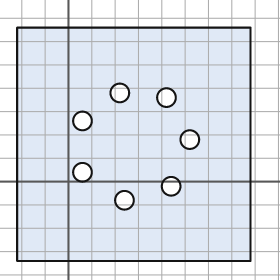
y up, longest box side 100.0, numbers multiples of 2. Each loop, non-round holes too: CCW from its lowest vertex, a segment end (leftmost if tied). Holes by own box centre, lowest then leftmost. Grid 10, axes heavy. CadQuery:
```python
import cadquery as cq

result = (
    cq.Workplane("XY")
    .moveTo(-22.0, -34.0)
    .lineTo(78.0, -34.0)
    .lineTo(78.0, 66.0)
    .lineTo(-22.0, 66.0)
    .close()
    .moveTo(24.0, -8.0)
    .circle(4.0)
    .moveTo(44.0, -2.0)
    .circle(4.0)
    .moveTo(6.0, 4.0)
    .circle(4.0)
    .moveTo(52.0, 18.0)
    .circle(4.0)
    .moveTo(6.0, 26.0)
    .circle(4.0)
    .moveTo(42.0, 36.0)
    .circle(4.0)
    .moveTo(22.0, 38.0)
    .circle(4.0)
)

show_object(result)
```